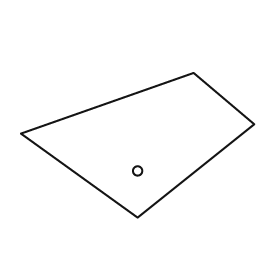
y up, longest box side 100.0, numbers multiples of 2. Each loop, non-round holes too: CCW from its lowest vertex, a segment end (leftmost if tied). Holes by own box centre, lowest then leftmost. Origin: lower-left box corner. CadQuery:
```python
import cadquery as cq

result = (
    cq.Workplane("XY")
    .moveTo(50.0, 0.0)
    .lineTo(100.0, 40.0)
    .lineTo(74.0, 62.0)
    .lineTo(0.0, 36.0)
    .close()
    .moveTo(50.0, 20.0)
    .circle(2.0)
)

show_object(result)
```